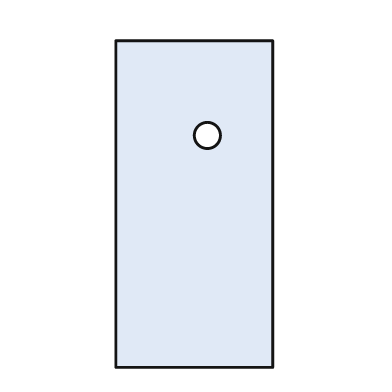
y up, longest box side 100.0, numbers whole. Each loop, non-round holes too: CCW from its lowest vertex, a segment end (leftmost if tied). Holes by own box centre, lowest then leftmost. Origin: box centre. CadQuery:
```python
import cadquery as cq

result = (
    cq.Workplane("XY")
    .moveTo(-24.0, -50.0)
    .lineTo(24.0, -50.0)
    .lineTo(24.0, 50.0)
    .lineTo(-24.0, 50.0)
    .close()
    .moveTo(4.0, 21.0)
    .circle(4.0)
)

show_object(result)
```